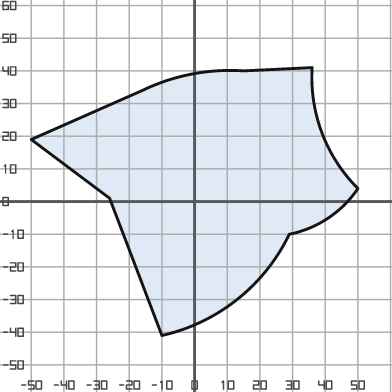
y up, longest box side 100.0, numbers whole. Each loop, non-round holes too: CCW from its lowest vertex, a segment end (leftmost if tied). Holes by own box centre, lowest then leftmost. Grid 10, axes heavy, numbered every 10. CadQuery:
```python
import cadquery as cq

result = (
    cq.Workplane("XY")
    .moveTo(-10.0, -41.0)
    .threePointArc((13.0, -30.0), (29.0, -10.0))
    .threePointArc((41.0, -5.0), (50.0, 4.0))
    .threePointArc((39.0, 21.0), (36.0, 41.0))
    .lineTo(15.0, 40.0)
    .threePointArc((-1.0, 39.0), (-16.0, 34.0))
    .lineTo(-50.0, 19.0)
    .lineTo(-26.0, 1.0)
    .close()
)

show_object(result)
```